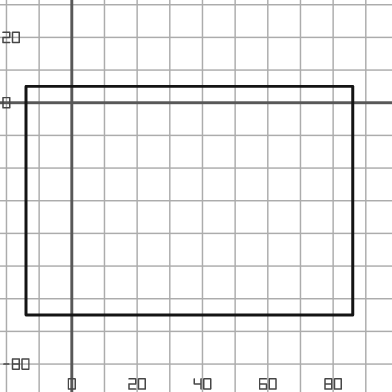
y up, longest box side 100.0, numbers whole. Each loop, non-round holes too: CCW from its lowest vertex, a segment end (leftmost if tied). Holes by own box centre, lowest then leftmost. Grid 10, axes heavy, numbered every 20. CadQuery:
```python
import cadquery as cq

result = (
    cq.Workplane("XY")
    .moveTo(-14.0, -65.0)
    .lineTo(86.0, -65.0)
    .lineTo(86.0, 5.0)
    .lineTo(-14.0, 5.0)
    .close()
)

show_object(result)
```